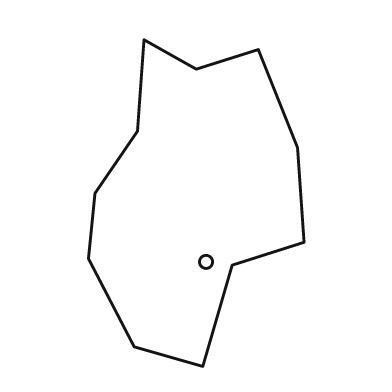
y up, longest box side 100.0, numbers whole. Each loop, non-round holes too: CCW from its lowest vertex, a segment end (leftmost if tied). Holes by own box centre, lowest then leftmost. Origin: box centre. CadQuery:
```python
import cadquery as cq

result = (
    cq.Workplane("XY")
    .moveTo(2.0, -50.0)
    .lineTo(11.0, -19.0)
    .lineTo(33.0, -12.0)
    .lineTo(31.0, 17.0)
    .lineTo(19.0, 47.0)
    .lineTo(0.0, 41.0)
    .lineTo(-16.0, 50.0)
    .lineTo(-18.0, 22.0)
    .lineTo(-31.0, 3.0)
    .lineTo(-33.0, -17.0)
    .lineTo(-19.0, -44.0)
    .close()
    .moveTo(3.0, -18.0)
    .circle(2.0)
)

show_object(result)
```